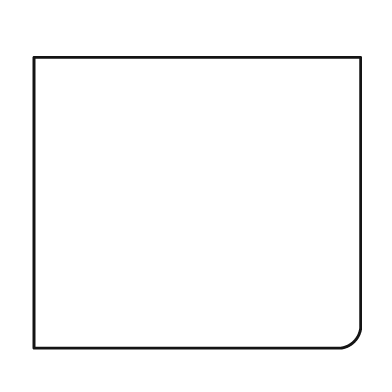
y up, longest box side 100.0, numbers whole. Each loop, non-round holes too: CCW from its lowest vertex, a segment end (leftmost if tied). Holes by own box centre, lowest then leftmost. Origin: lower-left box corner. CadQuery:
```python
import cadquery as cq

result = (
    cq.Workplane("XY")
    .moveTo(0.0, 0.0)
    .lineTo(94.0, 0.0)
    .threePointArc((98.0, 2.0), (100.0, 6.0))
    .lineTo(100.0, 89.0)
    .lineTo(0.0, 89.0)
    .close()
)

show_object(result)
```